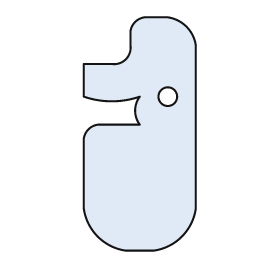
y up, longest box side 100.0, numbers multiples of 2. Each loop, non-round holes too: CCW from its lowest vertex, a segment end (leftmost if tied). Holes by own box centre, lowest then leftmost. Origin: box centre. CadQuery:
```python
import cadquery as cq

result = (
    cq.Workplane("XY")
    .moveTo(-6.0, -50.0)
    .lineTo(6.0, -50.0)
    .threePointArc((18.0, -44.0), (24.0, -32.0))
    .lineTo(24.0, 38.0)
    .threePointArc((20.0, 46.0), (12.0, 50.0))
    .lineTo(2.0, 50.0)
    .threePointArc((-2.0, 48.0), (-4.0, 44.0))
    .lineTo(-4.0, 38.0)
    .threePointArc((-6.0, 32.0), (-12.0, 30.0))
    .lineTo(-24.0, 30.0)
    .lineTo(-24.0, 16.0)
    .threePointArc((-12.0, 14.0), (0.0, 16.0))
    .threePointArc((-2.0, 10.0), (0.0, 4.0))
    .lineTo(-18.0, 4.0)
    .threePointArc((-22.0, 2.0), (-24.0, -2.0))
    .lineTo(-24.0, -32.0)
    .threePointArc((-18.0, -44.0), (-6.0, -50.0))
    .close()
    .moveTo(12.0, 16.0)
    .circle(4.0)
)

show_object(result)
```